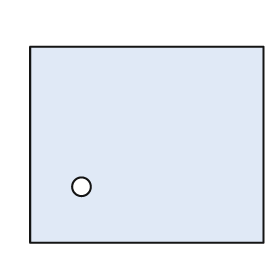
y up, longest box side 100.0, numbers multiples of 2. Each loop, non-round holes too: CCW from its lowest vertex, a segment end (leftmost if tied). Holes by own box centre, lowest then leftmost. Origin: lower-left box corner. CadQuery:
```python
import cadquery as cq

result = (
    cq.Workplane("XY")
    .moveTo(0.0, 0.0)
    .lineTo(100.0, 0.0)
    .lineTo(100.0, 84.0)
    .lineTo(0.0, 84.0)
    .close()
    .moveTo(22.0, 24.0)
    .circle(4.0)
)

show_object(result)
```